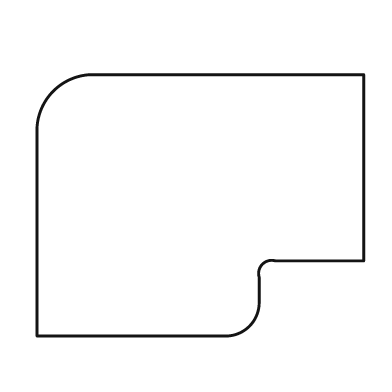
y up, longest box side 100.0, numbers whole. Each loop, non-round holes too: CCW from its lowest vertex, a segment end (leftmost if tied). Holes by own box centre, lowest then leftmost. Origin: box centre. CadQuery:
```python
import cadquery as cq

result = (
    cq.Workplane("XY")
    .moveTo(-50.0, -40.0)
    .lineTo(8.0, -40.0)
    .threePointArc((15.0, -37.0), (18.0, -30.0))
    .lineTo(18.0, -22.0)
    .threePointArc((19.0, -18.0), (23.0, -17.0))
    .lineTo(50.0, -17.0)
    .lineTo(50.0, 40.0)
    .lineTo(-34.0, 40.0)
    .threePointArc((-45.0, 35.0), (-50.0, 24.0))
    .close()
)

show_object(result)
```